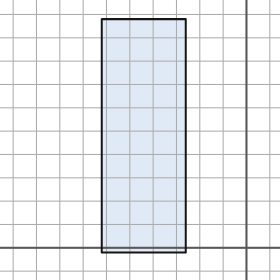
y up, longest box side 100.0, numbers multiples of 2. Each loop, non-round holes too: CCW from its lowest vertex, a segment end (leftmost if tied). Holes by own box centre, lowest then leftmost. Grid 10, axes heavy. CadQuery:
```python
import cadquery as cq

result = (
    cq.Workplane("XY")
    .moveTo(-62.0, -2.0)
    .lineTo(-26.0, -2.0)
    .lineTo(-26.0, 98.0)
    .lineTo(-62.0, 98.0)
    .close()
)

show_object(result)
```